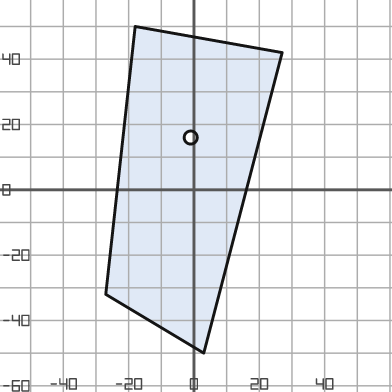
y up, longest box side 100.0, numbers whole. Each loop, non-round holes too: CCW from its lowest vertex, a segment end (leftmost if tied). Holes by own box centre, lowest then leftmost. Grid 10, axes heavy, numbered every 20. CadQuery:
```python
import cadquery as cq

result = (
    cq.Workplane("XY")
    .moveTo(3.0, -50.0)
    .lineTo(27.0, 42.0)
    .lineTo(-18.0, 50.0)
    .lineTo(-27.0, -32.0)
    .close()
    .moveTo(-1.0, 16.0)
    .circle(2.0)
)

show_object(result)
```